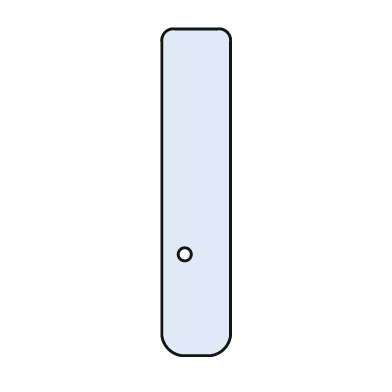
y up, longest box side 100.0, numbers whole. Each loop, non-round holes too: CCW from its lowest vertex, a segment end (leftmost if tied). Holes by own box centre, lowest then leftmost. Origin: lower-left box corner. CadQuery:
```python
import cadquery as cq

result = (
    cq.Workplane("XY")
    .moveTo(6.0, 0.0)
    .lineTo(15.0, 0.0)
    .threePointArc((19.0, 2.0), (21.0, 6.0))
    .lineTo(21.0, 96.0)
    .threePointArc((20.0, 99.0), (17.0, 100.0))
    .lineTo(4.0, 100.0)
    .threePointArc((1.0, 99.0), (0.0, 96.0))
    .lineTo(0.0, 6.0)
    .threePointArc((2.0, 2.0), (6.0, 0.0))
    .close()
    .moveTo(7.0, 31.0)
    .circle(2.0)
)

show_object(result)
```